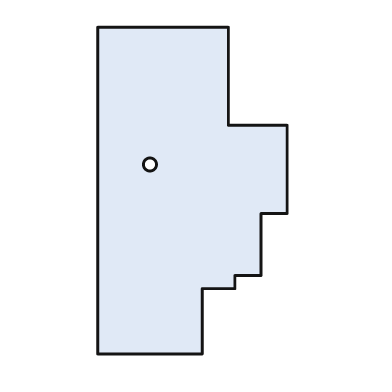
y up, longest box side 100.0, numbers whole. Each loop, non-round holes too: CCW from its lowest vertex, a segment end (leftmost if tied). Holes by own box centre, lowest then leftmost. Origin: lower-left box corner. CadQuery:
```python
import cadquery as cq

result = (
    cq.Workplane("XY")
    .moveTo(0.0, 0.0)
    .lineTo(32.0, 0.0)
    .lineTo(32.0, 20.0)
    .lineTo(42.0, 20.0)
    .lineTo(42.0, 24.0)
    .lineTo(50.0, 24.0)
    .lineTo(50.0, 43.0)
    .lineTo(58.0, 43.0)
    .lineTo(58.0, 70.0)
    .lineTo(40.0, 70.0)
    .lineTo(40.0, 100.0)
    .lineTo(0.0, 100.0)
    .close()
    .moveTo(16.0, 58.0)
    .circle(2.0)
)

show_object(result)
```